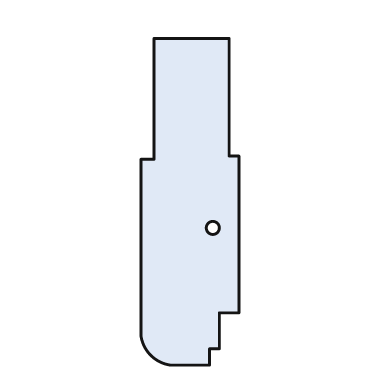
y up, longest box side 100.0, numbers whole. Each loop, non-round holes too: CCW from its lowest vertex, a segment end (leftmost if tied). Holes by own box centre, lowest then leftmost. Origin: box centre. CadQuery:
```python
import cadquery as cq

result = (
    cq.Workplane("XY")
    .moveTo(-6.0, -50.0)
    .lineTo(6.0, -50.0)
    .lineTo(6.0, -45.0)
    .lineTo(9.0, -45.0)
    .lineTo(9.0, -34.0)
    .lineTo(15.0, -34.0)
    .lineTo(15.0, 14.0)
    .lineTo(12.0, 14.0)
    .lineTo(12.0, 50.0)
    .lineTo(-11.0, 50.0)
    .lineTo(-11.0, 13.0)
    .lineTo(-15.0, 13.0)
    .lineTo(-15.0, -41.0)
    .threePointArc((-12.0, -47.0), (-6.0, -50.0))
    .close()
    .moveTo(7.0, -8.0)
    .circle(2.0)
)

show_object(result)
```